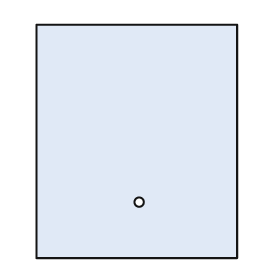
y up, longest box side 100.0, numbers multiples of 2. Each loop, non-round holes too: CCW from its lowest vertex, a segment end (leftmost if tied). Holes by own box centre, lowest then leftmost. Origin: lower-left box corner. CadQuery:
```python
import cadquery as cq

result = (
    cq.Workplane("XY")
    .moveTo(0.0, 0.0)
    .lineTo(86.0, 0.0)
    .lineTo(86.0, 100.0)
    .lineTo(0.0, 100.0)
    .close()
    .moveTo(44.0, 24.0)
    .circle(2.0)
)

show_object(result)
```